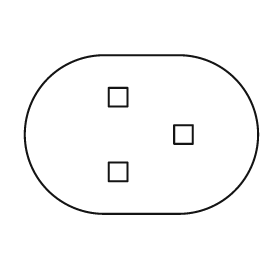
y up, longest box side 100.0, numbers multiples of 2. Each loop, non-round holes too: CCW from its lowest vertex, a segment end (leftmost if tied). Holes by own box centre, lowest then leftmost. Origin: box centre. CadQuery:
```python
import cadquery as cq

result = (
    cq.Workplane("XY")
    .moveTo(-16.0, -34.0)
    .lineTo(16.0, -34.0)
    .threePointArc((50.0, 0.0), (16.0, 34.0))
    .lineTo(-16.0, 34.0)
    .threePointArc((-50.0, 0.0), (-16.0, -34.0))
    .close()
    .moveTo(-14.0, -20.0)
    .lineTo(-6.0, -20.0)
    .lineTo(-6.0, -12.0)
    .lineTo(-14.0, -12.0)
    .close()
    .moveTo(14.0, -4.0)
    .lineTo(22.0, -4.0)
    .lineTo(22.0, 4.0)
    .lineTo(14.0, 4.0)
    .close()
    .moveTo(-14.0, 12.0)
    .lineTo(-6.0, 12.0)
    .lineTo(-6.0, 20.0)
    .lineTo(-14.0, 20.0)
    .close()
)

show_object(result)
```